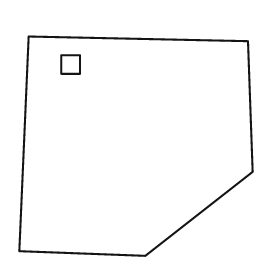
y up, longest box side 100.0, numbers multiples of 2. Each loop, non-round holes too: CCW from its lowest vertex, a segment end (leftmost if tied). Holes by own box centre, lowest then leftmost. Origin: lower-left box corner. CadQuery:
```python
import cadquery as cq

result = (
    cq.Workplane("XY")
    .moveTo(54.0, 0.0)
    .lineTo(100.0, 36.0)
    .lineTo(98.0, 92.0)
    .lineTo(4.0, 94.0)
    .lineTo(0.0, 2.0)
    .close()
    .moveTo(18.0, 78.0)
    .lineTo(26.0, 78.0)
    .lineTo(26.0, 86.0)
    .lineTo(18.0, 86.0)
    .close()
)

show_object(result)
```